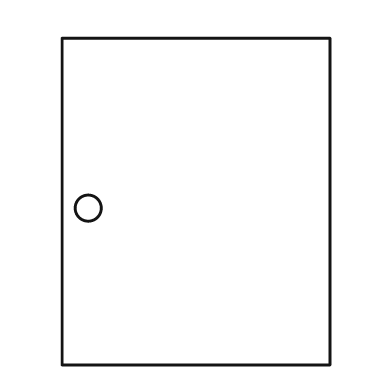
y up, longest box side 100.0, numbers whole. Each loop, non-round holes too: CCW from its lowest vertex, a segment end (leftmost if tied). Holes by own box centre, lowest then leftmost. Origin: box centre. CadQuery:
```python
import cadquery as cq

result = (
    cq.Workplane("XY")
    .moveTo(-41.0, -50.0)
    .lineTo(41.0, -50.0)
    .lineTo(41.0, 50.0)
    .lineTo(-41.0, 50.0)
    .close()
    .moveTo(-33.0, -2.0)
    .circle(4.0)
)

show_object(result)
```